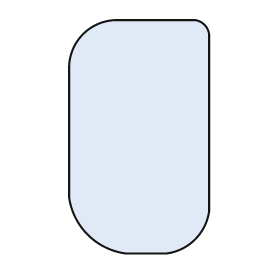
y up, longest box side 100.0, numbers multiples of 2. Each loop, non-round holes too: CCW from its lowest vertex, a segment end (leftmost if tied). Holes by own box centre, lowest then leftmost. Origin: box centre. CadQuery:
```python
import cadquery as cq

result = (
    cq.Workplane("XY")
    .moveTo(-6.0, -50.0)
    .lineTo(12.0, -50.0)
    .threePointArc((24.0, -44.0), (30.0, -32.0))
    .lineTo(30.0, 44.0)
    .threePointArc((28.0, 48.0), (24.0, 50.0))
    .lineTo(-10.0, 50.0)
    .threePointArc((-24.0, 44.0), (-30.0, 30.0))
    .lineTo(-30.0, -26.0)
    .threePointArc((-22.0, -42.0), (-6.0, -50.0))
    .close()
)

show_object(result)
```